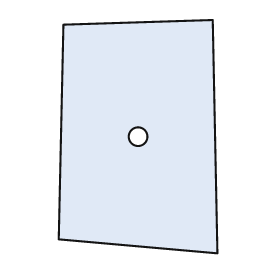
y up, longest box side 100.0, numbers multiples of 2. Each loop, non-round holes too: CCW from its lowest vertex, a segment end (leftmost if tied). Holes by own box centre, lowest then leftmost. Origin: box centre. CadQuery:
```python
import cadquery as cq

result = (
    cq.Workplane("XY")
    .moveTo(34.0, -50.0)
    .lineTo(32.0, 50.0)
    .lineTo(-32.0, 48.0)
    .lineTo(-34.0, -44.0)
    .close()
    .moveTo(0.0, 0.0)
    .circle(4.0)
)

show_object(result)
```